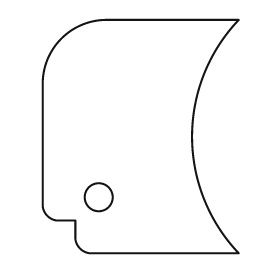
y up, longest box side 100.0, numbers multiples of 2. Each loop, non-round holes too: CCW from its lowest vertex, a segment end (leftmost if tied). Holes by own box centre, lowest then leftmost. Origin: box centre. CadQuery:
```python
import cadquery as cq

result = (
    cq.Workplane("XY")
    .moveTo(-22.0, -50.0)
    .lineTo(42.0, -50.0)
    .threePointArc((22.0, 0.0), (42.0, 50.0))
    .lineTo(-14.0, 50.0)
    .threePointArc((-34.0, 42.0), (-42.0, 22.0))
    .lineTo(-42.0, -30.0)
    .threePointArc((-40.0, -34.0), (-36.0, -36.0))
    .lineTo(-28.0, -36.0)
    .lineTo(-28.0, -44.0)
    .threePointArc((-26.0, -48.0), (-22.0, -50.0))
    .close()
    .moveTo(-18.0, -26.0)
    .circle(6.0)
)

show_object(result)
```